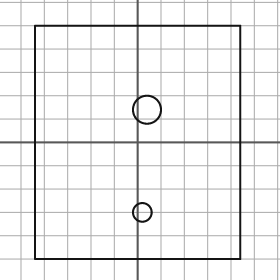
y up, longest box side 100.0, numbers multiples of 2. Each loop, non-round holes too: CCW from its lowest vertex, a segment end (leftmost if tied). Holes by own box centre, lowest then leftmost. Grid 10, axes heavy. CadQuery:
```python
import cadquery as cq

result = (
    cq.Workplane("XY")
    .moveTo(-44.0, -50.0)
    .lineTo(44.0, -50.0)
    .lineTo(44.0, 50.0)
    .lineTo(-44.0, 50.0)
    .close()
    .moveTo(2.0, -30.0)
    .circle(4.0)
    .moveTo(4.0, 14.0)
    .circle(6.0)
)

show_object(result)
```